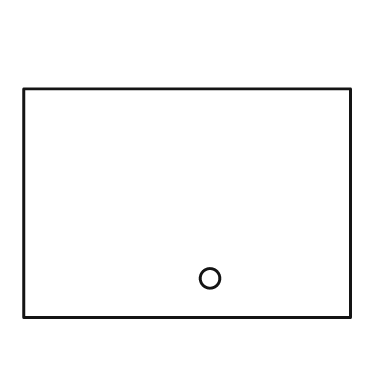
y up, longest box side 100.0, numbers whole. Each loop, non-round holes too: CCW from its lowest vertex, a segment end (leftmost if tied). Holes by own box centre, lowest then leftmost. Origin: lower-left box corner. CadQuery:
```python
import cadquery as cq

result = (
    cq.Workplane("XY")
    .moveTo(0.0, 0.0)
    .lineTo(100.0, 0.0)
    .lineTo(100.0, 70.0)
    .lineTo(0.0, 70.0)
    .close()
    .moveTo(57.0, 12.0)
    .circle(3.0)
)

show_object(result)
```